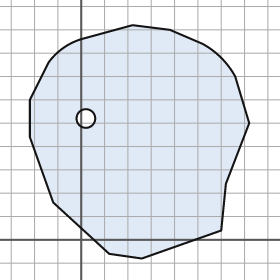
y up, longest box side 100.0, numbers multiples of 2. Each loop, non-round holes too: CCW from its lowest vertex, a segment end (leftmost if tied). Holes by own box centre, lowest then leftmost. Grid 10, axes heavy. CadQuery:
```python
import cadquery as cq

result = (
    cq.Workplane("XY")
    .moveTo(26.0, -8.0)
    .lineTo(60.0, 4.0)
    .lineTo(62.0, 24.0)
    .lineTo(72.0, 50.0)
    .lineTo(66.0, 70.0)
    .threePointArc((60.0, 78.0), (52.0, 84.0))
    .lineTo(38.0, 90.0)
    .lineTo(22.0, 92.0)
    .lineTo(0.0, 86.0)
    .threePointArc((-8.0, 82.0), (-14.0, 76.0))
    .lineTo(-22.0, 60.0)
    .lineTo(-22.0, 44.0)
    .lineTo(-12.0, 16.0)
    .lineTo(12.0, -6.0)
    .close()
    .moveTo(2.0, 52.0)
    .circle(4.0)
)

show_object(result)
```